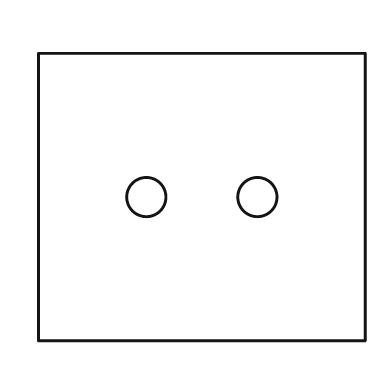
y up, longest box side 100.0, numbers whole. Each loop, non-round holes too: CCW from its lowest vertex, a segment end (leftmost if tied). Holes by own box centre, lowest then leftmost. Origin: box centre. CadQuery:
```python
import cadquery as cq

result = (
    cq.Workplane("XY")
    .moveTo(-50.0, -44.0)
    .lineTo(50.0, -44.0)
    .lineTo(50.0, 44.0)
    .lineTo(-50.0, 44.0)
    .close()
    .moveTo(-17.0, 0.0)
    .circle(6.0)
    .moveTo(17.0, 0.0)
    .circle(6.0)
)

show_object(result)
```